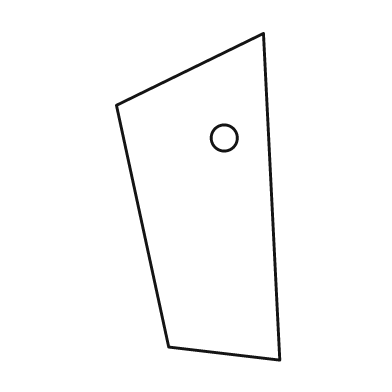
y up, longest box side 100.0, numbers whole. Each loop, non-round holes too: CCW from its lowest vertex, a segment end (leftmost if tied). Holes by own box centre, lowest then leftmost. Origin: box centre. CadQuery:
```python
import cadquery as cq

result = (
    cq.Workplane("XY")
    .moveTo(25.0, -50.0)
    .lineTo(20.0, 50.0)
    .lineTo(-25.0, 28.0)
    .lineTo(-9.0, -46.0)
    .close()
    .moveTo(8.0, 18.0)
    .circle(4.0)
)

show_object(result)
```